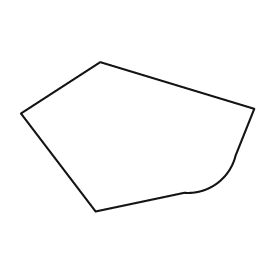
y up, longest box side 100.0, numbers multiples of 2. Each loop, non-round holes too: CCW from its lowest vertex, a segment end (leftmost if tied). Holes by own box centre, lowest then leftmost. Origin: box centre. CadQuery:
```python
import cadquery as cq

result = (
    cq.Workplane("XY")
    .moveTo(-18.0, -32.0)
    .lineTo(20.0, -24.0)
    .threePointArc((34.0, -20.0), (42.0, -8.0))
    .lineTo(50.0, 12.0)
    .lineTo(-16.0, 32.0)
    .lineTo(-50.0, 10.0)
    .close()
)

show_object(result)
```